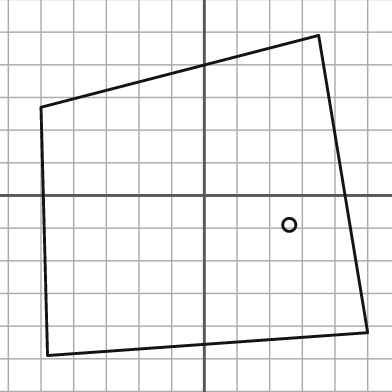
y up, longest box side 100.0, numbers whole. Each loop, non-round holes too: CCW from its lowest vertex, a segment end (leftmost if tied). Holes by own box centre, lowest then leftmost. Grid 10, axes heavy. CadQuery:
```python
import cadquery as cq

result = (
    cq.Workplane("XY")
    .moveTo(-48.0, -49.0)
    .lineTo(50.0, -42.0)
    .lineTo(35.0, 49.0)
    .lineTo(-50.0, 27.0)
    .close()
    .moveTo(26.0, -9.0)
    .circle(2.0)
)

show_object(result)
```